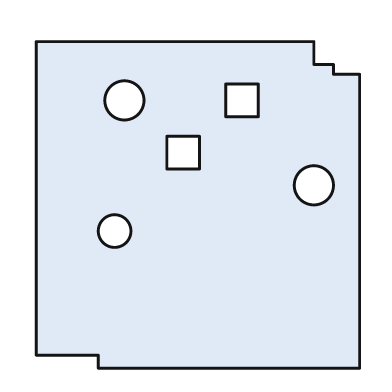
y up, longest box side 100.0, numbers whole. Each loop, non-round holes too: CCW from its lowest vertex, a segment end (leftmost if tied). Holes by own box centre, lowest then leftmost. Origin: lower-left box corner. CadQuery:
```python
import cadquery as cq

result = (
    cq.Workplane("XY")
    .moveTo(19.0, 0.0)
    .lineTo(99.0, 0.0)
    .lineTo(99.0, 90.0)
    .lineTo(91.0, 90.0)
    .lineTo(91.0, 93.0)
    .lineTo(85.0, 93.0)
    .lineTo(85.0, 100.0)
    .lineTo(0.0, 100.0)
    .lineTo(0.0, 4.0)
    .lineTo(19.0, 4.0)
    .close()
    .moveTo(24.0, 42.0)
    .circle(5.0)
    .moveTo(85.0, 56.0)
    .circle(6.0)
    .moveTo(40.0, 61.0)
    .lineTo(50.0, 61.0)
    .lineTo(50.0, 71.0)
    .lineTo(40.0, 71.0)
    .close()
    .moveTo(27.0, 82.0)
    .circle(6.0)
    .moveTo(58.0, 77.0)
    .lineTo(68.0, 77.0)
    .lineTo(68.0, 87.0)
    .lineTo(58.0, 87.0)
    .close()
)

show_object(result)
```